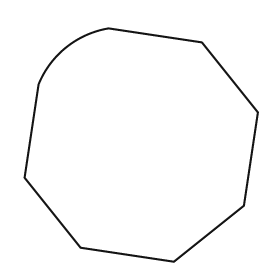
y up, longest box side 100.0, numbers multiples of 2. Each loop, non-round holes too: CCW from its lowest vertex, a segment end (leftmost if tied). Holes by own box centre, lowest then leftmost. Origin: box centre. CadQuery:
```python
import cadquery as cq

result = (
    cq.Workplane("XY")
    .moveTo(14.0, -50.0)
    .lineTo(44.0, -26.0)
    .lineTo(50.0, 14.0)
    .lineTo(26.0, 44.0)
    .lineTo(-14.0, 50.0)
    .threePointArc((-32.0, 42.0), (-44.0, 26.0))
    .lineTo(-50.0, -14.0)
    .lineTo(-26.0, -44.0)
    .close()
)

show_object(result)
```